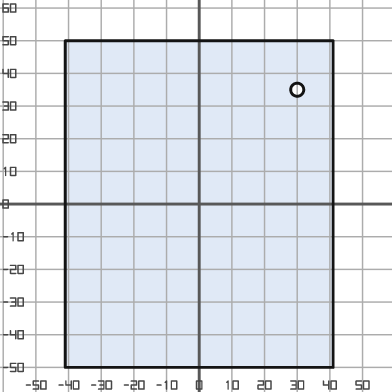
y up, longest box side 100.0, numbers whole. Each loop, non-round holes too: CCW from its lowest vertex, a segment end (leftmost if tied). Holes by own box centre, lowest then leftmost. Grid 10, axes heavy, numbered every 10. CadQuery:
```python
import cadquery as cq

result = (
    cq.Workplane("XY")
    .moveTo(-41.0, -50.0)
    .lineTo(41.0, -50.0)
    .lineTo(41.0, 50.0)
    .lineTo(-41.0, 50.0)
    .close()
    .moveTo(30.0, 35.0)
    .circle(2.0)
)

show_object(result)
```